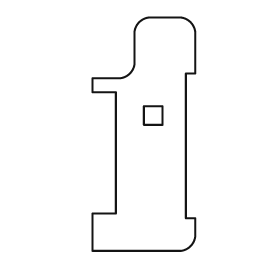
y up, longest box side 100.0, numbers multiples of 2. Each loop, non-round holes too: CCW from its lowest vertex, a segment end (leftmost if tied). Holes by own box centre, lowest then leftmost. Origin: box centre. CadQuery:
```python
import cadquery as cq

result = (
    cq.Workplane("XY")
    .moveTo(-22.0, -50.0)
    .lineTo(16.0, -50.0)
    .threePointArc((20.0, -48.0), (22.0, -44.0))
    .lineTo(22.0, -36.0)
    .lineTo(18.0, -36.0)
    .lineTo(18.0, 26.0)
    .lineTo(22.0, 26.0)
    .lineTo(22.0, 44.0)
    .threePointArc((20.0, 48.0), (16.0, 50.0))
    .lineTo(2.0, 50.0)
    .threePointArc((-2.0, 48.0), (-4.0, 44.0))
    .lineTo(-4.0, 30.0)
    .threePointArc((-6.0, 26.0), (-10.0, 24.0))
    .lineTo(-22.0, 24.0)
    .lineTo(-22.0, 18.0)
    .lineTo(-12.0, 18.0)
    .lineTo(-12.0, -34.0)
    .lineTo(-22.0, -34.0)
    .close()
    .moveTo(0.0, 4.0)
    .lineTo(8.0, 4.0)
    .lineTo(8.0, 12.0)
    .lineTo(0.0, 12.0)
    .close()
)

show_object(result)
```